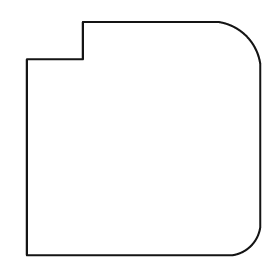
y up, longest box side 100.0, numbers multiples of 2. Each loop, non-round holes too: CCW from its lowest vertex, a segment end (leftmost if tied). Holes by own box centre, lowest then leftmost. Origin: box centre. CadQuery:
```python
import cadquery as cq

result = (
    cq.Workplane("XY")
    .moveTo(-50.0, -50.0)
    .lineTo(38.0, -50.0)
    .threePointArc((46.0, -46.0), (50.0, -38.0))
    .lineTo(50.0, 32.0)
    .threePointArc((44.0, 44.0), (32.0, 50.0))
    .lineTo(-26.0, 50.0)
    .lineTo(-26.0, 34.0)
    .lineTo(-50.0, 34.0)
    .close()
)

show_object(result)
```